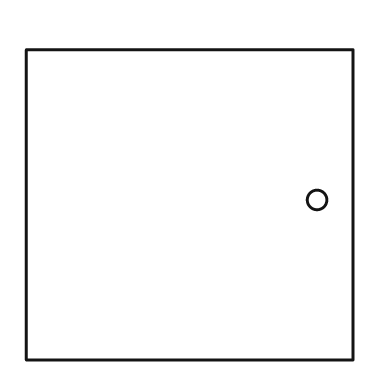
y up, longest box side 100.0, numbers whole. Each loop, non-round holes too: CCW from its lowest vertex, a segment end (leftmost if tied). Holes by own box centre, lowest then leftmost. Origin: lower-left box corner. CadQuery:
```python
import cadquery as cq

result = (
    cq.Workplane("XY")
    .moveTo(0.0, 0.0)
    .lineTo(100.0, 0.0)
    .lineTo(100.0, 95.0)
    .lineTo(0.0, 95.0)
    .close()
    .moveTo(89.0, 49.0)
    .circle(3.0)
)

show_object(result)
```